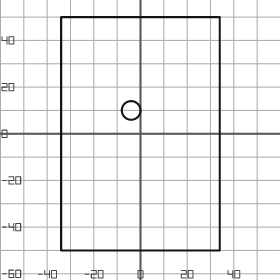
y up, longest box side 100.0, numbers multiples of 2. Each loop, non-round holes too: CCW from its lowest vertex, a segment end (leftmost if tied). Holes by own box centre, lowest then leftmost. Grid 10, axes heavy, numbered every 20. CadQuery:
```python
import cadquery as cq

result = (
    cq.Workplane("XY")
    .moveTo(-34.0, -50.0)
    .lineTo(34.0, -50.0)
    .lineTo(34.0, 50.0)
    .lineTo(-34.0, 50.0)
    .close()
    .moveTo(-4.0, 10.0)
    .circle(4.0)
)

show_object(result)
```